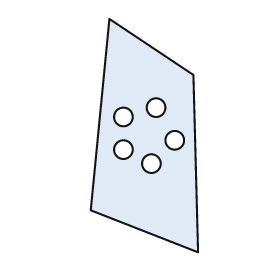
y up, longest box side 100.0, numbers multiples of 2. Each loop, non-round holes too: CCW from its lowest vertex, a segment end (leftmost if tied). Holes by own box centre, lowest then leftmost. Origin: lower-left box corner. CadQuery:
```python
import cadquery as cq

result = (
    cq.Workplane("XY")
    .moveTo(46.0, 0.0)
    .lineTo(44.0, 76.0)
    .lineTo(8.0, 100.0)
    .lineTo(0.0, 18.0)
    .close()
    .moveTo(26.0, 38.0)
    .circle(4.0)
    .moveTo(14.0, 44.0)
    .circle(4.0)
    .moveTo(36.0, 48.0)
    .circle(4.0)
    .moveTo(14.0, 58.0)
    .circle(4.0)
    .moveTo(28.0, 62.0)
    .circle(4.0)
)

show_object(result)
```